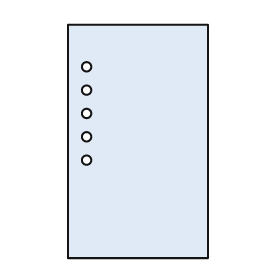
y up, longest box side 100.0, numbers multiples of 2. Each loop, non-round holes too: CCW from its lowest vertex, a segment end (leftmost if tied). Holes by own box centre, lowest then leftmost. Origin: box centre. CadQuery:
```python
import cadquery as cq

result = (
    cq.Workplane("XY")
    .moveTo(-30.0, -50.0)
    .lineTo(30.0, -50.0)
    .lineTo(30.0, 50.0)
    .lineTo(-30.0, 50.0)
    .close()
    .moveTo(-22.0, -8.0)
    .circle(2.0)
    .moveTo(-22.0, 2.0)
    .circle(2.0)
    .moveTo(-22.0, 12.0)
    .circle(2.0)
    .moveTo(-22.0, 22.0)
    .circle(2.0)
    .moveTo(-22.0, 32.0)
    .circle(2.0)
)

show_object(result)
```